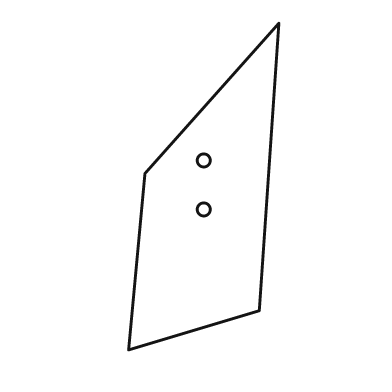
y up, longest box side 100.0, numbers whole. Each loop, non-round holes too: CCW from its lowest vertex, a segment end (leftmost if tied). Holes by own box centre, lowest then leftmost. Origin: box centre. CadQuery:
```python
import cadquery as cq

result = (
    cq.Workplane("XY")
    .moveTo(-23.0, -50.0)
    .lineTo(17.0, -38.0)
    .lineTo(23.0, 50.0)
    .lineTo(-18.0, 4.0)
    .close()
    .moveTo(0.0, -7.0)
    .circle(2.0)
    .moveTo(0.0, 8.0)
    .circle(2.0)
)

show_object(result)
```